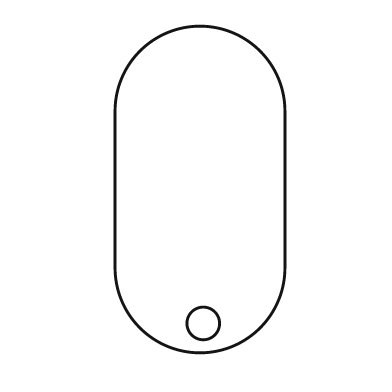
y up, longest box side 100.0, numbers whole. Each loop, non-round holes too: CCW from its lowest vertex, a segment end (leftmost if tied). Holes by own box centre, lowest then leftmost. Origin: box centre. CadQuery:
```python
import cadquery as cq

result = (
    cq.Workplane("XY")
    .moveTo(-26.0, -24.0)
    .threePointArc((0.0, -50.0), (26.0, -24.0))
    .lineTo(26.0, 24.0)
    .threePointArc((0.0, 50.0), (-26.0, 24.0))
    .close()
    .moveTo(1.0, -41.0)
    .circle(5.0)
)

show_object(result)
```